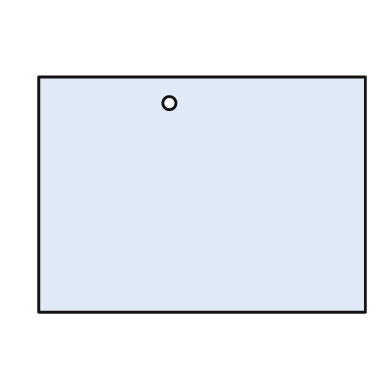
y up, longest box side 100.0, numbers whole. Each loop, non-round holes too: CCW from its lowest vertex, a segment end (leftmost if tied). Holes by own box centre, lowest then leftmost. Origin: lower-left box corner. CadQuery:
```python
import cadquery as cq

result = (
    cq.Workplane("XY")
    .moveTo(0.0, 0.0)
    .lineTo(100.0, 0.0)
    .lineTo(100.0, 72.0)
    .lineTo(0.0, 72.0)
    .close()
    .moveTo(40.0, 64.0)
    .circle(2.0)
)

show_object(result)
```